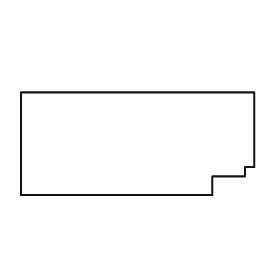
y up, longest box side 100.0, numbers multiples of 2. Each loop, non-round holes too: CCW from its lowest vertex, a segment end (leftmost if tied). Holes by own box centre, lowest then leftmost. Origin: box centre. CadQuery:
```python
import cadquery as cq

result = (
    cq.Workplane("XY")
    .moveTo(-50.0, -22.0)
    .lineTo(32.0, -22.0)
    .lineTo(32.0, -14.0)
    .lineTo(46.0, -14.0)
    .lineTo(46.0, -10.0)
    .lineTo(50.0, -10.0)
    .lineTo(50.0, 22.0)
    .lineTo(-50.0, 22.0)
    .close()
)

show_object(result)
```